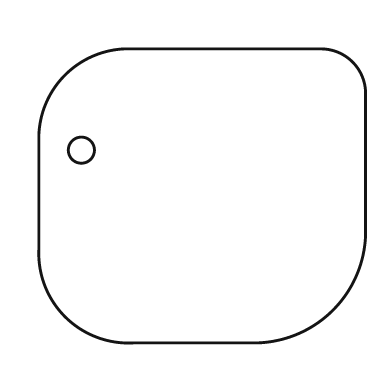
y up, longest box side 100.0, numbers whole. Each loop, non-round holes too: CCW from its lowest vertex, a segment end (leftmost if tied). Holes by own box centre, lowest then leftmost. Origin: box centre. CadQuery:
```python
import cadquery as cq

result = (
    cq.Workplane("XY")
    .moveTo(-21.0, -45.0)
    .lineTo(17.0, -45.0)
    .threePointArc((40.0, -35.0), (50.0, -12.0))
    .lineTo(50.0, 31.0)
    .threePointArc((46.0, 41.0), (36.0, 45.0))
    .lineTo(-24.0, 45.0)
    .threePointArc((-42.0, 37.0), (-50.0, 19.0))
    .lineTo(-50.0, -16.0)
    .threePointArc((-42.0, -37.0), (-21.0, -45.0))
    .close()
    .moveTo(-37.0, 14.0)
    .circle(4.0)
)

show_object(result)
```